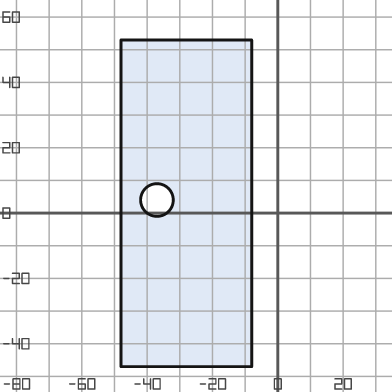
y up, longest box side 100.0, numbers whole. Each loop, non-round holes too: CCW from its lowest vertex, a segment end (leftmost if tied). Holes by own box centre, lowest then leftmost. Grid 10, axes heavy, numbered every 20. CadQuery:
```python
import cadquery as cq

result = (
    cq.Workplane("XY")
    .moveTo(-48.0, -47.0)
    .lineTo(-8.0, -47.0)
    .lineTo(-8.0, 53.0)
    .lineTo(-48.0, 53.0)
    .close()
    .moveTo(-37.0, 4.0)
    .circle(5.0)
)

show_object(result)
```